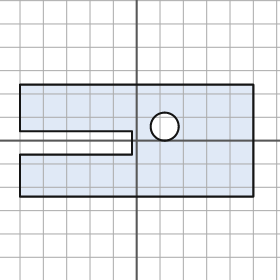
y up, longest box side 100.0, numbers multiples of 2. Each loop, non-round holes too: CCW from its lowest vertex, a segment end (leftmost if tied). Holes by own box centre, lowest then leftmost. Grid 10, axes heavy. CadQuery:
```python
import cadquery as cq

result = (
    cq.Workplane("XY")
    .moveTo(-50.0, -24.0)
    .lineTo(50.0, -24.0)
    .lineTo(50.0, 24.0)
    .lineTo(-50.0, 24.0)
    .lineTo(-50.0, 4.0)
    .lineTo(-2.0, 4.0)
    .lineTo(-2.0, -6.0)
    .lineTo(-50.0, -6.0)
    .close()
    .moveTo(12.0, 6.0)
    .circle(6.0)
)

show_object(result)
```